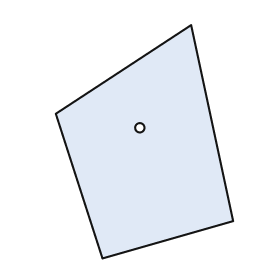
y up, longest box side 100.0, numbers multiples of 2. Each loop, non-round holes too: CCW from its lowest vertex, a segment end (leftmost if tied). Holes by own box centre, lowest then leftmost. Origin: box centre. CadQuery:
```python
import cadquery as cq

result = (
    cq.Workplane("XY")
    .moveTo(-18.0, -50.0)
    .lineTo(38.0, -34.0)
    .lineTo(20.0, 50.0)
    .lineTo(-38.0, 12.0)
    .close()
    .moveTo(-2.0, 6.0)
    .circle(2.0)
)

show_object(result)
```